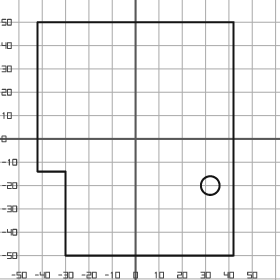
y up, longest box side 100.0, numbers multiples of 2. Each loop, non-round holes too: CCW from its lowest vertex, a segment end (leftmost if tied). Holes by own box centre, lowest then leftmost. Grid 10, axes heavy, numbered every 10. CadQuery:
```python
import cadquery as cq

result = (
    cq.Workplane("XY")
    .moveTo(-30.0, -50.0)
    .lineTo(42.0, -50.0)
    .lineTo(42.0, 50.0)
    .lineTo(-42.0, 50.0)
    .lineTo(-42.0, -14.0)
    .lineTo(-30.0, -14.0)
    .close()
    .moveTo(32.0, -20.0)
    .circle(4.0)
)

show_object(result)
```